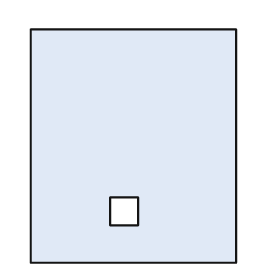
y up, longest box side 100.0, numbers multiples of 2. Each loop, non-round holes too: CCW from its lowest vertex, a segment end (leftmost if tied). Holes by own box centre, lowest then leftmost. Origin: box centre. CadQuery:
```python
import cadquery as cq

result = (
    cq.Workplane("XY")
    .moveTo(-44.0, -50.0)
    .lineTo(44.0, -50.0)
    .lineTo(44.0, 50.0)
    .lineTo(-44.0, 50.0)
    .close()
    .moveTo(-10.0, -34.0)
    .lineTo(2.0, -34.0)
    .lineTo(2.0, -22.0)
    .lineTo(-10.0, -22.0)
    .close()
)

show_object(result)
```